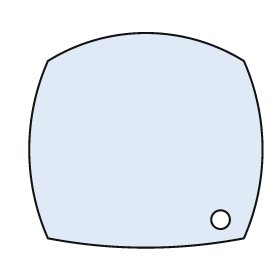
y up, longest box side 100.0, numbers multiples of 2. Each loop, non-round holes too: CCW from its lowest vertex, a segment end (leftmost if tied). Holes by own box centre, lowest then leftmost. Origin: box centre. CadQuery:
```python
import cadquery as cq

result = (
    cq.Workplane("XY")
    .moveTo(-42.0, -42.0)
    .threePointArc((0.0, -46.0), (42.0, -42.0))
    .threePointArc((50.0, -4.0), (42.0, 34.0))
    .threePointArc((0.0, 46.0), (-42.0, 34.0))
    .threePointArc((-50.0, -4.0), (-42.0, -42.0))
    .close()
    .moveTo(32.0, -34.0)
    .circle(4.0)
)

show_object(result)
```